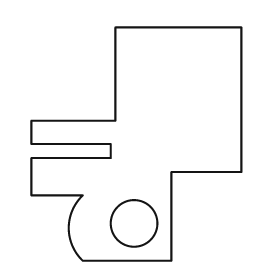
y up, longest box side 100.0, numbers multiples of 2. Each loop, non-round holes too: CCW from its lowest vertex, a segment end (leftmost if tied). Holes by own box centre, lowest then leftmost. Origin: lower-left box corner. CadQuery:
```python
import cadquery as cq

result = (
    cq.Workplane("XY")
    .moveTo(22.0, 0.0)
    .lineTo(60.0, 0.0)
    .lineTo(60.0, 38.0)
    .lineTo(90.0, 38.0)
    .lineTo(90.0, 100.0)
    .lineTo(36.0, 100.0)
    .lineTo(36.0, 60.0)
    .lineTo(0.0, 60.0)
    .lineTo(0.0, 50.0)
    .lineTo(34.0, 50.0)
    .lineTo(34.0, 44.0)
    .lineTo(0.0, 44.0)
    .lineTo(0.0, 28.0)
    .lineTo(22.0, 28.0)
    .threePointArc((16.0, 14.0), (22.0, 0.0))
    .close()
    .moveTo(44.0, 16.0)
    .circle(10.0)
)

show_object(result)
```